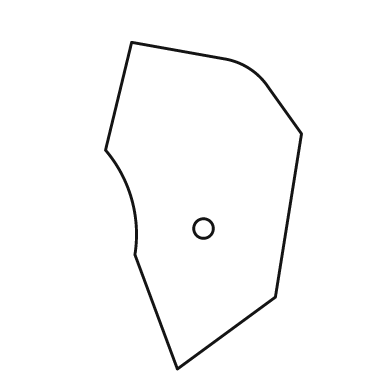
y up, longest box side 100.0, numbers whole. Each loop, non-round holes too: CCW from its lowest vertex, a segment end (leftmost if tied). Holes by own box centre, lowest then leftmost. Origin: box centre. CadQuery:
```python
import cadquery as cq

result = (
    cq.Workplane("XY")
    .moveTo(-8.0, -50.0)
    .lineTo(22.0, -28.0)
    .lineTo(30.0, 22.0)
    .lineTo(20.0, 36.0)
    .threePointArc((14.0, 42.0), (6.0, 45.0))
    .lineTo(-22.0, 50.0)
    .lineTo(-30.0, 17.0)
    .threePointArc((-22.0, 2.0), (-21.0, -15.0))
    .close()
    .moveTo(0.0, -7.0)
    .circle(3.0)
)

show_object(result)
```